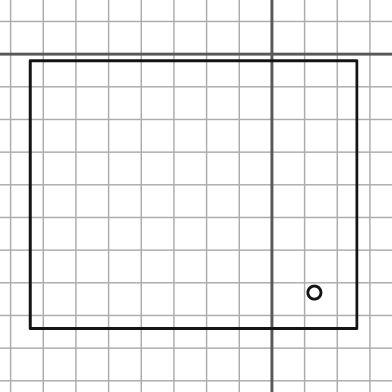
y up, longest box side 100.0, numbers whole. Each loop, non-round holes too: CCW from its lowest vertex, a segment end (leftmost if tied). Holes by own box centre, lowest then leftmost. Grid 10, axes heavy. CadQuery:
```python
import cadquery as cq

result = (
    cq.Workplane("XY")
    .moveTo(-74.0, -84.0)
    .lineTo(26.0, -84.0)
    .lineTo(26.0, -2.0)
    .lineTo(-74.0, -2.0)
    .close()
    .moveTo(13.0, -73.0)
    .circle(2.0)
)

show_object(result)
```